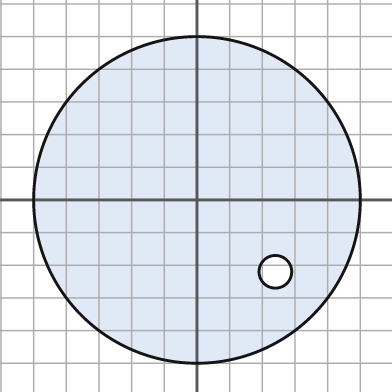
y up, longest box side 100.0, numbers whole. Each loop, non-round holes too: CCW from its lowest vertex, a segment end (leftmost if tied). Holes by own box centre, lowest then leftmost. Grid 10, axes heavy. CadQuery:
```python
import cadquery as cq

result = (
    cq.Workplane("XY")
    .moveTo(0.0, 0.0)
    .circle(50.0)
    .moveTo(24.0, -22.0)
    .circle(5.0)
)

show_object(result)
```